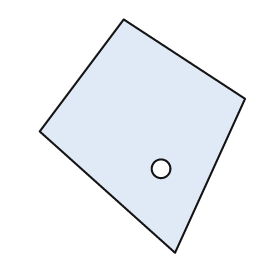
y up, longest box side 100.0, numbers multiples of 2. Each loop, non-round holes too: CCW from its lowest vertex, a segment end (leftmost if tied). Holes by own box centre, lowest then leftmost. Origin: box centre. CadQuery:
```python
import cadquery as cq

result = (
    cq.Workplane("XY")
    .moveTo(14.0, -50.0)
    .lineTo(44.0, 16.0)
    .lineTo(-8.0, 50.0)
    .lineTo(-44.0, 2.0)
    .close()
    .moveTo(8.0, -14.0)
    .circle(4.0)
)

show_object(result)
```